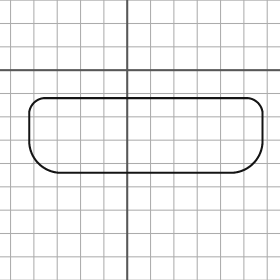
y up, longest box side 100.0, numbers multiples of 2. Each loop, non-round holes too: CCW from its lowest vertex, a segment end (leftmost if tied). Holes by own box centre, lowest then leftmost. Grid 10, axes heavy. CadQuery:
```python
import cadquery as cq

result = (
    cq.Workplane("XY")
    .moveTo(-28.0, -44.0)
    .lineTo(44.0, -44.0)
    .threePointArc((54.0, -40.0), (58.0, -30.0))
    .lineTo(58.0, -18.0)
    .threePointArc((56.0, -14.0), (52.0, -12.0))
    .lineTo(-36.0, -12.0)
    .threePointArc((-40.0, -14.0), (-42.0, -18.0))
    .lineTo(-42.0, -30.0)
    .threePointArc((-38.0, -40.0), (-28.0, -44.0))
    .close()
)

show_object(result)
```